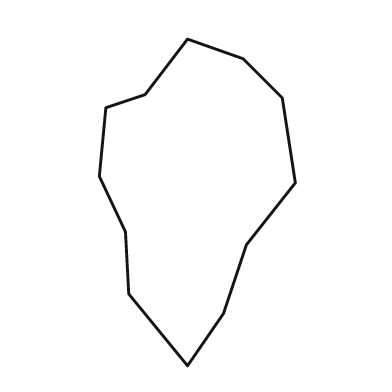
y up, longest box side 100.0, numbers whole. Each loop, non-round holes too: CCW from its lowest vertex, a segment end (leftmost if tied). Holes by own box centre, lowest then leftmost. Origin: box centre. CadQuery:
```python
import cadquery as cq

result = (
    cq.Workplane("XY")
    .moveTo(-3.0, -50.0)
    .lineTo(8.0, -34.0)
    .lineTo(15.0, -13.0)
    .lineTo(30.0, 6.0)
    .lineTo(26.0, 32.0)
    .lineTo(14.0, 44.0)
    .lineTo(-3.0, 50.0)
    .lineTo(-16.0, 33.0)
    .lineTo(-28.0, 29.0)
    .lineTo(-30.0, 8.0)
    .lineTo(-22.0, -9.0)
    .lineTo(-21.0, -28.0)
    .close()
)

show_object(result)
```